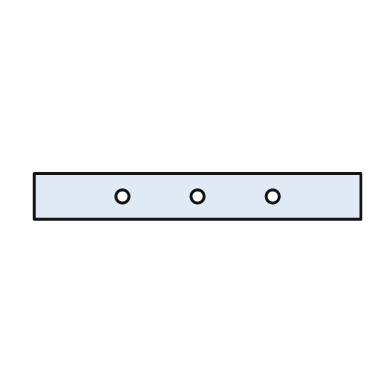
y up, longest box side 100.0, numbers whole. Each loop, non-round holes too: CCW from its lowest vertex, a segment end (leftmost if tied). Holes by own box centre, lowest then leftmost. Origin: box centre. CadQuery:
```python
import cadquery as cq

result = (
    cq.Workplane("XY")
    .moveTo(-50.0, -7.0)
    .lineTo(50.0, -7.0)
    .lineTo(50.0, 7.0)
    .lineTo(-50.0, 7.0)
    .close()
    .moveTo(-23.0, 0.0)
    .circle(2.0)
    .moveTo(0.0, 0.0)
    .circle(2.0)
    .moveTo(23.0, 0.0)
    .circle(2.0)
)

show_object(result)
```